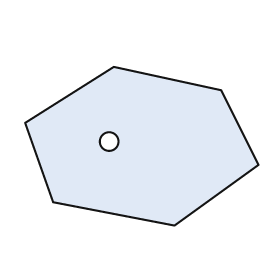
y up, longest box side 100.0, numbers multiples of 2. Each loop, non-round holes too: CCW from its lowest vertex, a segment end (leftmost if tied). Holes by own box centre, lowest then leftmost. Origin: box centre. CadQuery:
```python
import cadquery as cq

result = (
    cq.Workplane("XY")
    .moveTo(14.0, -34.0)
    .lineTo(50.0, -8.0)
    .lineTo(34.0, 24.0)
    .lineTo(-12.0, 34.0)
    .lineTo(-50.0, 10.0)
    .lineTo(-38.0, -24.0)
    .close()
    .moveTo(-14.0, 2.0)
    .circle(4.0)
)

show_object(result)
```